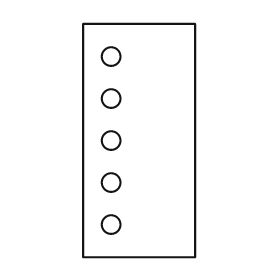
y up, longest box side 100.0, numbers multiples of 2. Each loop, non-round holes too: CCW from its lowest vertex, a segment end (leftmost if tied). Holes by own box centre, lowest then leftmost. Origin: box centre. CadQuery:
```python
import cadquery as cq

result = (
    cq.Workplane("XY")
    .moveTo(-24.0, -50.0)
    .lineTo(24.0, -50.0)
    .lineTo(24.0, 50.0)
    .lineTo(-24.0, 50.0)
    .close()
    .moveTo(-12.0, -36.0)
    .circle(4.0)
    .moveTo(-12.0, -18.0)
    .circle(4.0)
    .moveTo(-12.0, 0.0)
    .circle(4.0)
    .moveTo(-12.0, 18.0)
    .circle(4.0)
    .moveTo(-12.0, 36.0)
    .circle(4.0)
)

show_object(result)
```